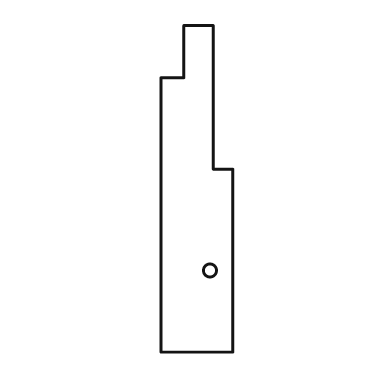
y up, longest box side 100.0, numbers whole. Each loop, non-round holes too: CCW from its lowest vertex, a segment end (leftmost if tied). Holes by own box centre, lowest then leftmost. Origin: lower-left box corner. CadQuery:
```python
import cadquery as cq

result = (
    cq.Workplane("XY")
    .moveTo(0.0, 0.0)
    .lineTo(22.0, 0.0)
    .lineTo(22.0, 56.0)
    .lineTo(16.0, 56.0)
    .lineTo(16.0, 100.0)
    .lineTo(7.0, 100.0)
    .lineTo(7.0, 84.0)
    .lineTo(0.0, 84.0)
    .close()
    .moveTo(15.0, 25.0)
    .circle(2.0)
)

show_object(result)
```